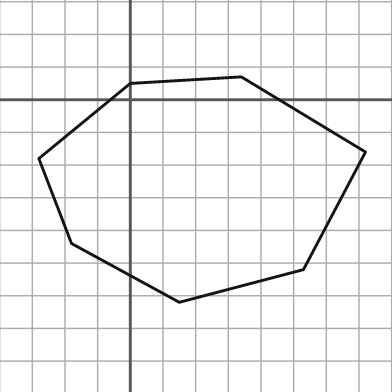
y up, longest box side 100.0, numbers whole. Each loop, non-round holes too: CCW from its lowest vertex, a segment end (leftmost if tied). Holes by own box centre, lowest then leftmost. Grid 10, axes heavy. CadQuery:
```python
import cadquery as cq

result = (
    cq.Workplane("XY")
    .moveTo(15.0, -62.0)
    .lineTo(53.0, -52.0)
    .lineTo(72.0, -16.0)
    .lineTo(34.0, 7.0)
    .lineTo(0.0, 5.0)
    .lineTo(-28.0, -18.0)
    .lineTo(-18.0, -44.0)
    .close()
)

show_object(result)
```